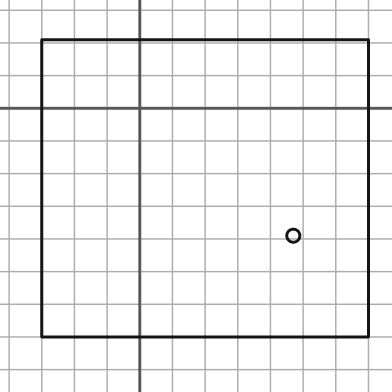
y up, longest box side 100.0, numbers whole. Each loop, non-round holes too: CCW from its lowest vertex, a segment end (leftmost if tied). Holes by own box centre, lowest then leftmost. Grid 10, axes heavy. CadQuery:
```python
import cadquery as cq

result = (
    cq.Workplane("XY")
    .moveTo(-30.0, -70.0)
    .lineTo(70.0, -70.0)
    .lineTo(70.0, 21.0)
    .lineTo(-30.0, 21.0)
    .close()
    .moveTo(47.0, -39.0)
    .circle(2.0)
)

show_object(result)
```